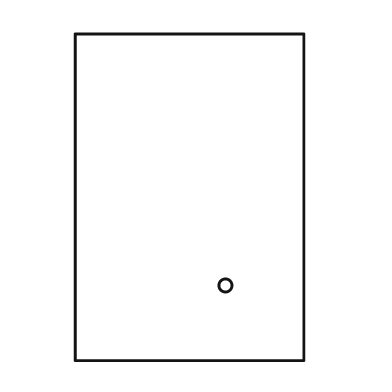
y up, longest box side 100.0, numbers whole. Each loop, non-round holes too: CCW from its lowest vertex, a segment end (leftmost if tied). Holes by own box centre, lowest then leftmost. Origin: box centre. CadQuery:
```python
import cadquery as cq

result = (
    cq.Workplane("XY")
    .moveTo(-35.0, -50.0)
    .lineTo(35.0, -50.0)
    .lineTo(35.0, 50.0)
    .lineTo(-35.0, 50.0)
    .close()
    .moveTo(11.0, -27.0)
    .circle(2.0)
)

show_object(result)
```